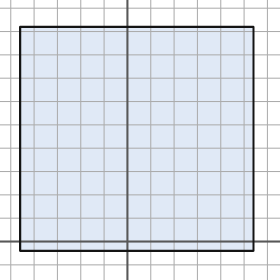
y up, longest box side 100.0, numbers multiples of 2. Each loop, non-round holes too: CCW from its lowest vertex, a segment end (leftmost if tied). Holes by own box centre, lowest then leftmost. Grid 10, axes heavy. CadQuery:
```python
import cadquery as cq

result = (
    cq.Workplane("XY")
    .moveTo(-46.0, -4.0)
    .lineTo(54.0, -4.0)
    .lineTo(54.0, 92.0)
    .lineTo(-46.0, 92.0)
    .close()
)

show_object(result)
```